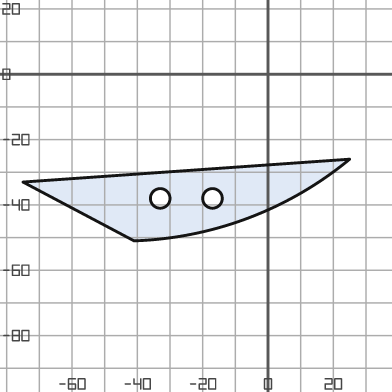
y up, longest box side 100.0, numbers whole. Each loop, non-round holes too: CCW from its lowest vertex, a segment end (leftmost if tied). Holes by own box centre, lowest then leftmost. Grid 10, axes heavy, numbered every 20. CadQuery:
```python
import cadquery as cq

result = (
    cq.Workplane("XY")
    .moveTo(-41.0, -51.0)
    .threePointArc((-6.0, -44.0), (25.0, -26.0))
    .lineTo(-75.0, -33.0)
    .close()
    .moveTo(-33.0, -38.0)
    .circle(3.0)
    .moveTo(-17.0, -38.0)
    .circle(3.0)
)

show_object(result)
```